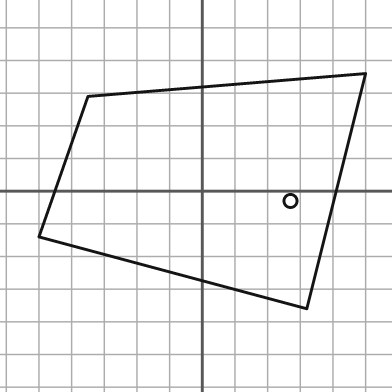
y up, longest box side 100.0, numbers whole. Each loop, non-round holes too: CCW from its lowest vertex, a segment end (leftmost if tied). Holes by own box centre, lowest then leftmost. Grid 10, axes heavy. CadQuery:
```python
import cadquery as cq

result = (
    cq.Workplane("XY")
    .moveTo(32.0, -36.0)
    .lineTo(50.0, 36.0)
    .lineTo(-35.0, 29.0)
    .lineTo(-50.0, -14.0)
    .close()
    .moveTo(27.0, -3.0)
    .circle(2.0)
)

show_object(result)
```